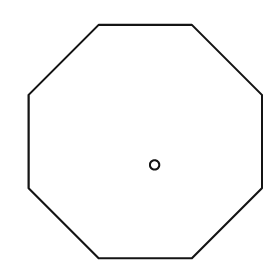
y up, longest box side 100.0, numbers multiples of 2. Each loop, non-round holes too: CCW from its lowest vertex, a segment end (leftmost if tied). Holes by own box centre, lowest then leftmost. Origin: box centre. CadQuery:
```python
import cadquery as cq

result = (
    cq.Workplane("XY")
    .moveTo(-20.0, -50.0)
    .lineTo(20.0, -50.0)
    .lineTo(50.0, -20.0)
    .lineTo(50.0, 20.0)
    .lineTo(20.0, 50.0)
    .lineTo(-20.0, 50.0)
    .lineTo(-50.0, 20.0)
    .lineTo(-50.0, -20.0)
    .close()
    .moveTo(4.0, -10.0)
    .circle(2.0)
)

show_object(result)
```